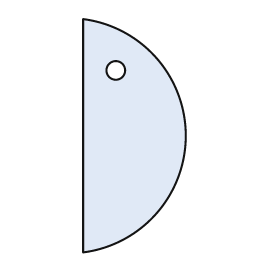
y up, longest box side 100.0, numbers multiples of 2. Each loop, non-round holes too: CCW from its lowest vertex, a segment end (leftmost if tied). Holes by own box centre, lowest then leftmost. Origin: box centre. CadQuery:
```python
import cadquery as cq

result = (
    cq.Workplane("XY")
    .moveTo(-22.0, -50.0)
    .threePointArc((22.0, 0.0), (-22.0, 50.0))
    .close()
    .moveTo(-8.0, 28.0)
    .circle(4.0)
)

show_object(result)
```